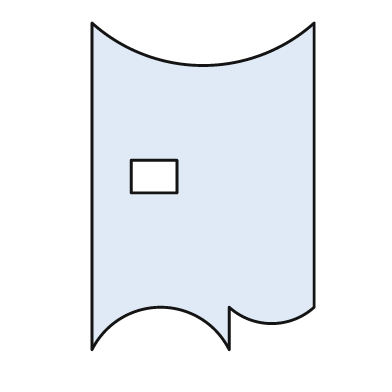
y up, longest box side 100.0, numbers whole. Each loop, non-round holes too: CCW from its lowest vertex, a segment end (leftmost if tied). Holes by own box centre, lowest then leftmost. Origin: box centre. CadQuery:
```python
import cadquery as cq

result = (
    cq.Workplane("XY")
    .moveTo(-34.0, -50.0)
    .threePointArc((-13.0, -37.0), (8.0, -50.0))
    .lineTo(8.0, -37.0)
    .threePointArc((21.0, -42.0), (34.0, -37.0))
    .lineTo(34.0, 50.0)
    .threePointArc((0.0, 37.0), (-34.0, 50.0))
    .close()
    .moveTo(-22.0, -2.0)
    .lineTo(-8.0, -2.0)
    .lineTo(-8.0, 8.0)
    .lineTo(-22.0, 8.0)
    .close()
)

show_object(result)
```